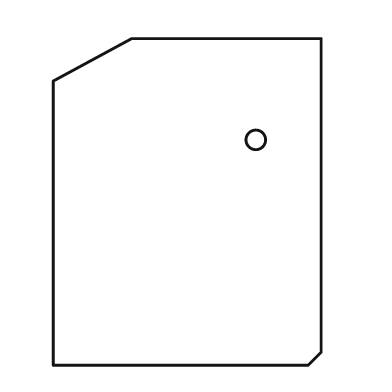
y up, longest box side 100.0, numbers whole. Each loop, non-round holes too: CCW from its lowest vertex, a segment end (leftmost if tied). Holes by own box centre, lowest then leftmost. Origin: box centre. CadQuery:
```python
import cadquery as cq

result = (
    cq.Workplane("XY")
    .moveTo(-41.0, -50.0)
    .lineTo(37.0, -50.0)
    .lineTo(41.0, -46.0)
    .lineTo(41.0, 50.0)
    .lineTo(-17.0, 50.0)
    .lineTo(-41.0, 37.0)
    .close()
    .moveTo(21.0, 19.0)
    .circle(3.0)
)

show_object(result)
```